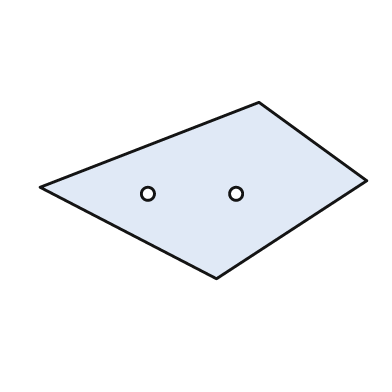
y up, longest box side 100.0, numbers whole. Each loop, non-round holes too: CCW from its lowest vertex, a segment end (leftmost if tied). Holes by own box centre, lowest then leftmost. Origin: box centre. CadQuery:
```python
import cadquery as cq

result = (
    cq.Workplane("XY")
    .moveTo(4.0, -27.0)
    .lineTo(50.0, 3.0)
    .lineTo(17.0, 27.0)
    .lineTo(-50.0, 1.0)
    .close()
    .moveTo(-17.0, -1.0)
    .circle(2.0)
    .moveTo(10.0, -1.0)
    .circle(2.0)
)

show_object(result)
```